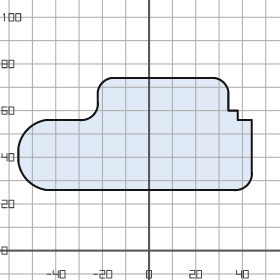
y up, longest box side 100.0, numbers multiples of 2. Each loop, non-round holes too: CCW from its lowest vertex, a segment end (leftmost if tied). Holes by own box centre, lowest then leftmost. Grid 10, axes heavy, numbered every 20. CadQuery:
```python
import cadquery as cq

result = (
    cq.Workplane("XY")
    .moveTo(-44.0, 26.0)
    .lineTo(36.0, 26.0)
    .threePointArc((42.0, 28.0), (44.0, 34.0))
    .lineTo(44.0, 56.0)
    .lineTo(38.0, 56.0)
    .lineTo(38.0, 60.0)
    .lineTo(34.0, 60.0)
    .lineTo(34.0, 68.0)
    .threePointArc((32.0, 72.0), (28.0, 74.0))
    .lineTo(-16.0, 74.0)
    .threePointArc((-20.0, 72.0), (-22.0, 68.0))
    .lineTo(-22.0, 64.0)
    .threePointArc((-24.0, 58.0), (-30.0, 56.0))
    .lineTo(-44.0, 56.0)
    .threePointArc((-52.0, 52.0), (-56.0, 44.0))
    .lineTo(-56.0, 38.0)
    .threePointArc((-52.0, 30.0), (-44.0, 26.0))
    .close()
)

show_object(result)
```